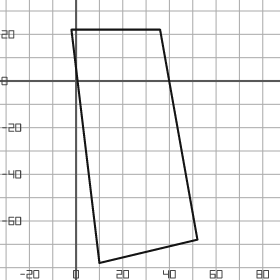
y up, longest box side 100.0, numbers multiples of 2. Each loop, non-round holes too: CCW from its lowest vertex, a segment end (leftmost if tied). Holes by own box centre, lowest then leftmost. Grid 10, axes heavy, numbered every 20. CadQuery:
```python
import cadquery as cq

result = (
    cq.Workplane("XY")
    .moveTo(10.0, -78.0)
    .lineTo(52.0, -68.0)
    .lineTo(36.0, 22.0)
    .lineTo(-2.0, 22.0)
    .close()
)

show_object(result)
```